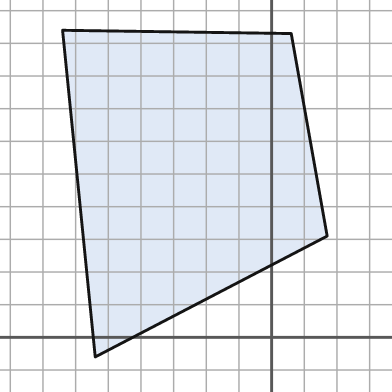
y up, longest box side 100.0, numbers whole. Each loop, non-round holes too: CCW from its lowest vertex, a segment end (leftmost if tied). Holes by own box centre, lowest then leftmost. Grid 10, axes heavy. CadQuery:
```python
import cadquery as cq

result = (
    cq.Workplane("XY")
    .moveTo(-54.0, -6.0)
    .lineTo(17.0, 31.0)
    .lineTo(6.0, 93.0)
    .lineTo(-64.0, 94.0)
    .close()
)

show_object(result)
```